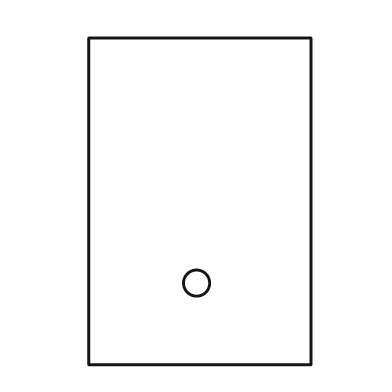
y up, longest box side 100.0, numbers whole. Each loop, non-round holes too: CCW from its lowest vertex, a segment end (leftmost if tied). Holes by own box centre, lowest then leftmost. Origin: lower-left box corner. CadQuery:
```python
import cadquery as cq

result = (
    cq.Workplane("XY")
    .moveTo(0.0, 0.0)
    .lineTo(68.0, 0.0)
    .lineTo(68.0, 100.0)
    .lineTo(0.0, 100.0)
    .close()
    .moveTo(33.0, 25.0)
    .circle(4.0)
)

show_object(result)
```